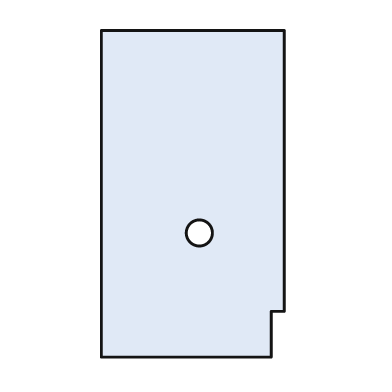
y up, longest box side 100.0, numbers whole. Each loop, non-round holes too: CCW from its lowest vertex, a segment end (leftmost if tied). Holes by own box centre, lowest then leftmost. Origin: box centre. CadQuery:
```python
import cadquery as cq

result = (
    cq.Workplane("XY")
    .moveTo(-28.0, -50.0)
    .lineTo(24.0, -50.0)
    .lineTo(24.0, -36.0)
    .lineTo(28.0, -36.0)
    .lineTo(28.0, 50.0)
    .lineTo(-28.0, 50.0)
    .close()
    .moveTo(2.0, -12.0)
    .circle(4.0)
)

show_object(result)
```